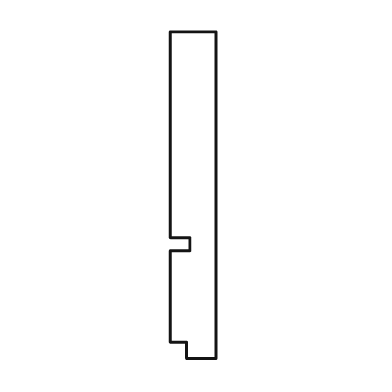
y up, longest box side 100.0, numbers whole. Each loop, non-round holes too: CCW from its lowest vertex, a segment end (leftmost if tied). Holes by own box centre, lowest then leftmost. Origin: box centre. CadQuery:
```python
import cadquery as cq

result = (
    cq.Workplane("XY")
    .moveTo(-2.0, -50.0)
    .lineTo(7.0, -50.0)
    .lineTo(7.0, 50.0)
    .lineTo(-7.0, 50.0)
    .lineTo(-7.0, -13.0)
    .lineTo(-1.0, -13.0)
    .lineTo(-1.0, -17.0)
    .lineTo(-7.0, -17.0)
    .lineTo(-7.0, -45.0)
    .lineTo(-2.0, -45.0)
    .close()
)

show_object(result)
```